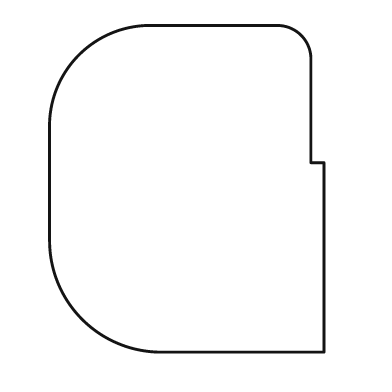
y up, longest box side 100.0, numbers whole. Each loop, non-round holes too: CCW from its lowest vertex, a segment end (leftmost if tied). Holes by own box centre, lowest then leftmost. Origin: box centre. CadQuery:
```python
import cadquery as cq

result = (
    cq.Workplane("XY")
    .moveTo(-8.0, -50.0)
    .lineTo(42.0, -50.0)
    .lineTo(42.0, 8.0)
    .lineTo(38.0, 8.0)
    .lineTo(38.0, 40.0)
    .threePointArc((35.0, 47.0), (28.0, 50.0))
    .lineTo(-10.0, 50.0)
    .threePointArc((-33.0, 41.0), (-42.0, 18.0))
    .lineTo(-42.0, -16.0)
    .threePointArc((-32.0, -40.0), (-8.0, -50.0))
    .close()
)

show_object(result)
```